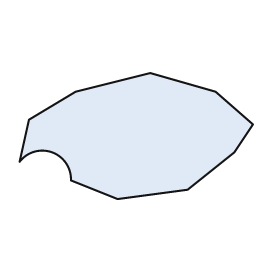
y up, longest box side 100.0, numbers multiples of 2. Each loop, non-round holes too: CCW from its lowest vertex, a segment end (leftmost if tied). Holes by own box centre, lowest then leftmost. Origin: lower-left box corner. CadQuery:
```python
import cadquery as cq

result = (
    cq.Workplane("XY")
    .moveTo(42.0, 0.0)
    .lineTo(72.0, 4.0)
    .lineTo(92.0, 20.0)
    .lineTo(100.0, 32.0)
    .lineTo(84.0, 46.0)
    .lineTo(56.0, 54.0)
    .lineTo(24.0, 46.0)
    .lineTo(4.0, 34.0)
    .lineTo(0.0, 16.0)
    .threePointArc((14.0, 20.0), (22.0, 8.0))
    .close()
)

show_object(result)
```